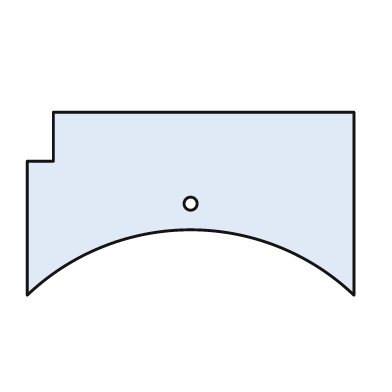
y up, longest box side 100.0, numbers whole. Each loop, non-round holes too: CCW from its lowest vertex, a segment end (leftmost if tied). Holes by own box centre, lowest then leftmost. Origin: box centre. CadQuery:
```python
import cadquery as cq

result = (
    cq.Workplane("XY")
    .moveTo(-50.0, -28.0)
    .threePointArc((0.0, -8.0), (50.0, -28.0))
    .lineTo(50.0, 28.0)
    .lineTo(-42.0, 28.0)
    .lineTo(-42.0, 13.0)
    .lineTo(-50.0, 13.0)
    .close()
    .moveTo(0.0, 0.0)
    .circle(2.0)
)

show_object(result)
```